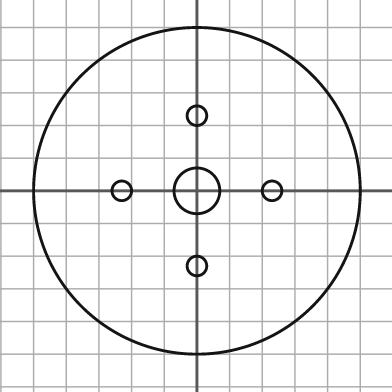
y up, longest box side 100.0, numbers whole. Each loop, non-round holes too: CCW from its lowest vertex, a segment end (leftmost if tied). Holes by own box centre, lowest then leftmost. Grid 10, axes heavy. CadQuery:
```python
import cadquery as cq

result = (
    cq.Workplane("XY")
    .moveTo(0.0, 0.0)
    .circle(50.0)
    .moveTo(0.0, -23.0)
    .circle(3.0)
    .moveTo(-23.0, 0.0)
    .circle(3.0)
    .moveTo(0.0, 0.0)
    .circle(7.0)
    .moveTo(23.0, 0.0)
    .circle(3.0)
    .moveTo(0.0, 23.0)
    .circle(3.0)
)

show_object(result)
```